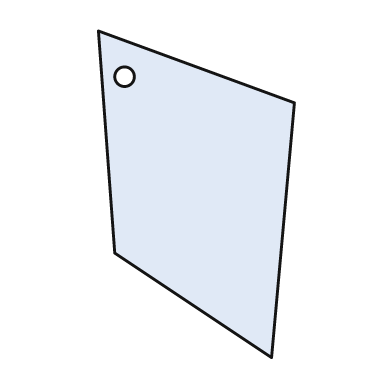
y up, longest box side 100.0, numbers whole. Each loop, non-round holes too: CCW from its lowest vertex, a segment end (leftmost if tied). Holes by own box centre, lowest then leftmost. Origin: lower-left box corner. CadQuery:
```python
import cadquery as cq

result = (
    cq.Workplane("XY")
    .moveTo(53.0, 0.0)
    .lineTo(60.0, 78.0)
    .lineTo(0.0, 100.0)
    .lineTo(5.0, 32.0)
    .close()
    .moveTo(8.0, 86.0)
    .circle(3.0)
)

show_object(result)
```